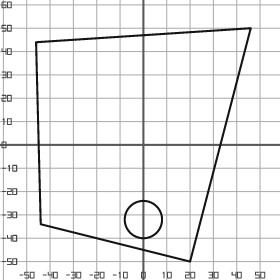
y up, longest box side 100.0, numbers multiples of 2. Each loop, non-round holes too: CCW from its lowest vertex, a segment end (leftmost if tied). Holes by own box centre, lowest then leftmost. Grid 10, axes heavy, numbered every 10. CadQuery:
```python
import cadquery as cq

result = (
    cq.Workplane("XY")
    .moveTo(20.0, -50.0)
    .lineTo(46.0, 50.0)
    .lineTo(-46.0, 44.0)
    .lineTo(-44.0, -34.0)
    .close()
    .moveTo(0.0, -32.0)
    .circle(8.0)
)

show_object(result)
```